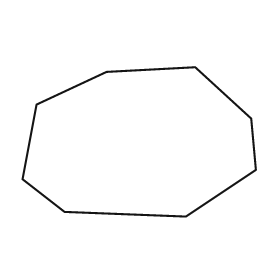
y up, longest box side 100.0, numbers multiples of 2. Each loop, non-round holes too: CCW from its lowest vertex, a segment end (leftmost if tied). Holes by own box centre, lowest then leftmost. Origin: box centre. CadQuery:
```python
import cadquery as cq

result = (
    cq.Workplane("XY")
    .moveTo(20.0, -32.0)
    .lineTo(50.0, -12.0)
    .lineTo(48.0, 10.0)
    .lineTo(24.0, 32.0)
    .lineTo(-14.0, 30.0)
    .lineTo(-44.0, 16.0)
    .lineTo(-50.0, -16.0)
    .lineTo(-32.0, -30.0)
    .close()
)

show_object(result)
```